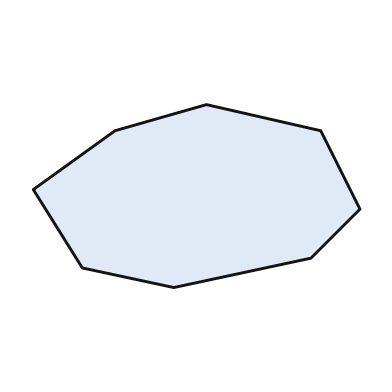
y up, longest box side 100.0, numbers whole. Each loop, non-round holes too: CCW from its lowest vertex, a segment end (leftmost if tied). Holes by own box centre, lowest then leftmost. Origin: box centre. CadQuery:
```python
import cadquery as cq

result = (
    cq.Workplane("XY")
    .moveTo(-7.0, -28.0)
    .lineTo(35.0, -19.0)
    .lineTo(50.0, -4.0)
    .lineTo(38.0, 20.0)
    .lineTo(3.0, 28.0)
    .lineTo(-25.0, 20.0)
    .lineTo(-50.0, 2.0)
    .lineTo(-35.0, -22.0)
    .close()
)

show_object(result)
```